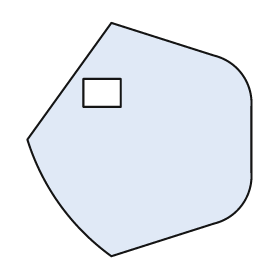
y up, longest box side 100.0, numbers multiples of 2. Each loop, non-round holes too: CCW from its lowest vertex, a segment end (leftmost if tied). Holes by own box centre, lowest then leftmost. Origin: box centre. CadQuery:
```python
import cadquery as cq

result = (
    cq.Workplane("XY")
    .moveTo(-12.0, -50.0)
    .lineTo(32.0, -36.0)
    .threePointArc((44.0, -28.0), (48.0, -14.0))
    .lineTo(48.0, 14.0)
    .threePointArc((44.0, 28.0), (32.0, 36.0))
    .lineTo(-12.0, 50.0)
    .lineTo(-48.0, 0.0)
    .threePointArc((-34.0, -28.0), (-12.0, -50.0))
    .close()
    .moveTo(-24.0, 14.0)
    .lineTo(-8.0, 14.0)
    .lineTo(-8.0, 26.0)
    .lineTo(-24.0, 26.0)
    .close()
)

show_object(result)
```